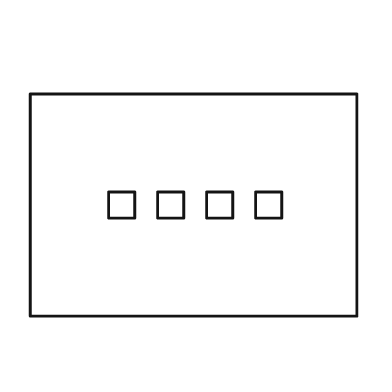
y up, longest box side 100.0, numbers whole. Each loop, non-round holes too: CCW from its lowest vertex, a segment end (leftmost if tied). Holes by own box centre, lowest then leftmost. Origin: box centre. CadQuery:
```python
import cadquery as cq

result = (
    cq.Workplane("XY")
    .moveTo(-50.0, -34.0)
    .lineTo(50.0, -34.0)
    .lineTo(50.0, 34.0)
    .lineTo(-50.0, 34.0)
    .close()
    .moveTo(-26.0, -4.0)
    .lineTo(-18.0, -4.0)
    .lineTo(-18.0, 4.0)
    .lineTo(-26.0, 4.0)
    .close()
    .moveTo(-11.0, -4.0)
    .lineTo(-3.0, -4.0)
    .lineTo(-3.0, 4.0)
    .lineTo(-11.0, 4.0)
    .close()
    .moveTo(4.0, -4.0)
    .lineTo(12.0, -4.0)
    .lineTo(12.0, 4.0)
    .lineTo(4.0, 4.0)
    .close()
    .moveTo(19.0, -4.0)
    .lineTo(27.0, -4.0)
    .lineTo(27.0, 4.0)
    .lineTo(19.0, 4.0)
    .close()
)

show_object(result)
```